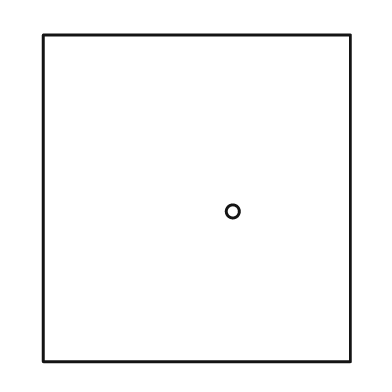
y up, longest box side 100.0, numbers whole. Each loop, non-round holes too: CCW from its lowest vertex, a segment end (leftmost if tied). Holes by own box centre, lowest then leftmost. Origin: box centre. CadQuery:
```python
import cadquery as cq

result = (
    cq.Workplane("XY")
    .moveTo(-47.0, -50.0)
    .lineTo(47.0, -50.0)
    .lineTo(47.0, 50.0)
    .lineTo(-47.0, 50.0)
    .close()
    .moveTo(11.0, -4.0)
    .circle(2.0)
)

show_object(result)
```